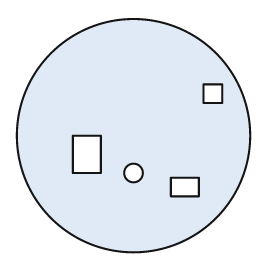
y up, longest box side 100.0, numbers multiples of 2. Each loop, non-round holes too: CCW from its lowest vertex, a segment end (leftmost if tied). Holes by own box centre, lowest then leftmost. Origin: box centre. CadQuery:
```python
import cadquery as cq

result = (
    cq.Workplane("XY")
    .moveTo(0.0, 0.0)
    .circle(50.0)
    .moveTo(16.0, -26.0)
    .lineTo(28.0, -26.0)
    .lineTo(28.0, -18.0)
    .lineTo(16.0, -18.0)
    .close()
    .moveTo(0.0, -16.0)
    .circle(4.0)
    .moveTo(-26.0, -16.0)
    .lineTo(-14.0, -16.0)
    .lineTo(-14.0, 0.0)
    .lineTo(-26.0, 0.0)
    .close()
    .moveTo(30.0, 14.0)
    .lineTo(38.0, 14.0)
    .lineTo(38.0, 22.0)
    .lineTo(30.0, 22.0)
    .close()
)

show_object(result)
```